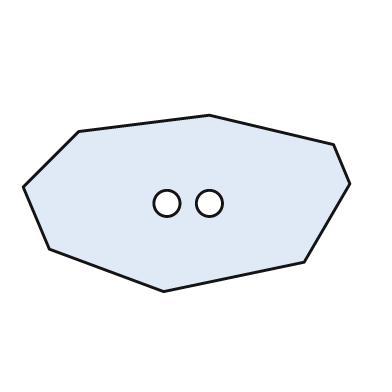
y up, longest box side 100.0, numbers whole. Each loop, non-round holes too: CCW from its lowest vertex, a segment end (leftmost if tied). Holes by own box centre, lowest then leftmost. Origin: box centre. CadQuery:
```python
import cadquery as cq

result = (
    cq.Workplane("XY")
    .moveTo(-7.0, -27.0)
    .lineTo(36.0, -18.0)
    .lineTo(50.0, 6.0)
    .lineTo(45.0, 18.0)
    .lineTo(7.0, 27.0)
    .lineTo(-33.0, 22.0)
    .lineTo(-50.0, 5.0)
    .lineTo(-42.0, -14.0)
    .close()
    .moveTo(-6.0, 0.0)
    .circle(4.0)
    .moveTo(7.0, 0.0)
    .circle(4.0)
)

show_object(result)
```